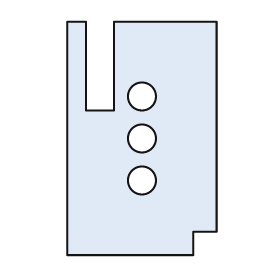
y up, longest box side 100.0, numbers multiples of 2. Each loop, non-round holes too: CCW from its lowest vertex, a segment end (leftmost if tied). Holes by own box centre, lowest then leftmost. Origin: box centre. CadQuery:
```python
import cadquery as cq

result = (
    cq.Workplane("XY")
    .moveTo(-32.0, -50.0)
    .lineTo(22.0, -50.0)
    .lineTo(22.0, -40.0)
    .lineTo(32.0, -40.0)
    .lineTo(32.0, 50.0)
    .lineTo(-12.0, 50.0)
    .lineTo(-12.0, 12.0)
    .lineTo(-24.0, 12.0)
    .lineTo(-24.0, 50.0)
    .lineTo(-32.0, 50.0)
    .close()
    .moveTo(0.0, -18.0)
    .circle(6.0)
    .moveTo(0.0, 0.0)
    .circle(6.0)
    .moveTo(0.0, 18.0)
    .circle(6.0)
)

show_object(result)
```